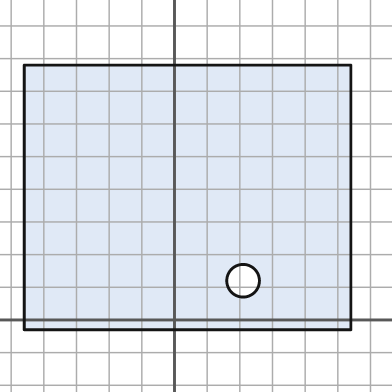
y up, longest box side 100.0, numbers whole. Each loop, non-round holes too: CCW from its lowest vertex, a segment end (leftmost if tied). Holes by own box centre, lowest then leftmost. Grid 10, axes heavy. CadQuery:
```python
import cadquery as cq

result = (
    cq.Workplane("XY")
    .moveTo(-46.0, -3.0)
    .lineTo(54.0, -3.0)
    .lineTo(54.0, 78.0)
    .lineTo(-46.0, 78.0)
    .close()
    .moveTo(21.0, 12.0)
    .circle(5.0)
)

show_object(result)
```